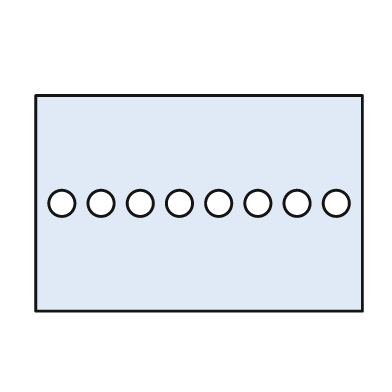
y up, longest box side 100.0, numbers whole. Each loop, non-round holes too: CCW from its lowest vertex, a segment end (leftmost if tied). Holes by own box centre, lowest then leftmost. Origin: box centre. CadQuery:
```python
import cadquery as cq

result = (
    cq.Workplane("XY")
    .moveTo(-50.0, -33.0)
    .lineTo(50.0, -33.0)
    .lineTo(50.0, 33.0)
    .lineTo(-50.0, 33.0)
    .close()
    .moveTo(-42.0, 0.0)
    .circle(4.0)
    .moveTo(-30.0, 0.0)
    .circle(4.0)
    .moveTo(-18.0, 0.0)
    .circle(4.0)
    .moveTo(-6.0, 0.0)
    .circle(4.0)
    .moveTo(6.0, 0.0)
    .circle(4.0)
    .moveTo(18.0, 0.0)
    .circle(4.0)
    .moveTo(30.0, 0.0)
    .circle(4.0)
    .moveTo(42.0, 0.0)
    .circle(4.0)
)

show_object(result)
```